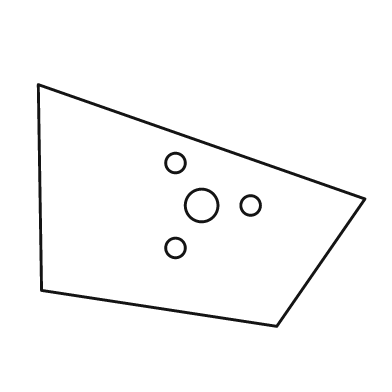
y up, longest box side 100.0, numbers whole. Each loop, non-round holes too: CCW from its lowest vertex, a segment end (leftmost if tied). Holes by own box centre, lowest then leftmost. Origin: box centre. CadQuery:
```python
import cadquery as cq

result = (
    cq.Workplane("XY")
    .moveTo(23.0, -37.0)
    .lineTo(50.0, 2.0)
    .lineTo(-50.0, 37.0)
    .lineTo(-49.0, -26.0)
    .close()
    .moveTo(-8.0, -13.0)
    .circle(3.0)
    .moveTo(0.0, 0.0)
    .circle(5.0)
    .moveTo(15.0, 0.0)
    .circle(3.0)
    .moveTo(-8.0, 13.0)
    .circle(3.0)
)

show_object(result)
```